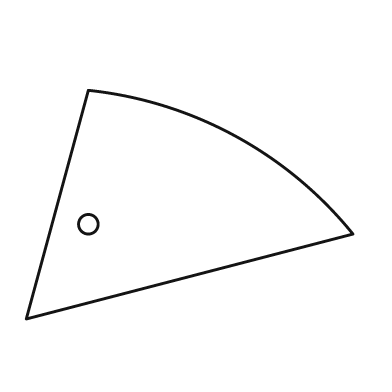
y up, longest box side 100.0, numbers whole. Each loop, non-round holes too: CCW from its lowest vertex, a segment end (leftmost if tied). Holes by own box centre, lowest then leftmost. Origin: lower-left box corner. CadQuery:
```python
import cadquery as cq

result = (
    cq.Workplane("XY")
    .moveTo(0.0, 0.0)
    .lineTo(100.0, 26.0)
    .threePointArc((64.0, 56.0), (19.0, 70.0))
    .close()
    .moveTo(19.0, 29.0)
    .circle(3.0)
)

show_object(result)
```